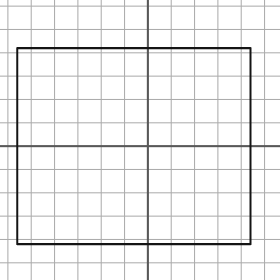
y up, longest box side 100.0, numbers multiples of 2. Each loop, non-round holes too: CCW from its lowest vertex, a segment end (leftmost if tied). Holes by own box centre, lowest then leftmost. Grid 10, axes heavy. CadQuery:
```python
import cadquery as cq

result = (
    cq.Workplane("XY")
    .moveTo(-56.0, -42.0)
    .lineTo(44.0, -42.0)
    .lineTo(44.0, 42.0)
    .lineTo(-56.0, 42.0)
    .close()
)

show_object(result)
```